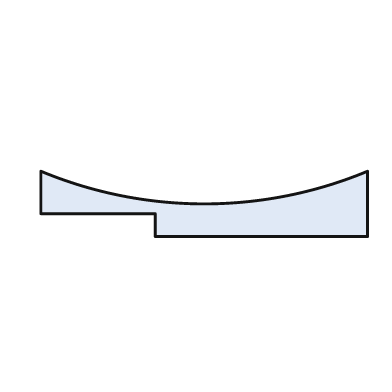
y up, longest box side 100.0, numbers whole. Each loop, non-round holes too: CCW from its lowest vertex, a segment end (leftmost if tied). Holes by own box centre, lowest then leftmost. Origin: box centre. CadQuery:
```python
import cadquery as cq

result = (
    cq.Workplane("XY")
    .moveTo(-15.0, -10.0)
    .lineTo(50.0, -10.0)
    .lineTo(50.0, 10.0)
    .threePointArc((0.0, 0.0), (-50.0, 10.0))
    .lineTo(-50.0, -3.0)
    .lineTo(-15.0, -3.0)
    .close()
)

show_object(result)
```